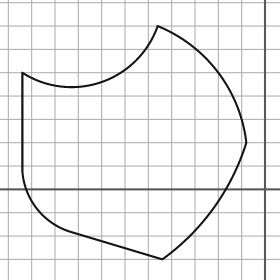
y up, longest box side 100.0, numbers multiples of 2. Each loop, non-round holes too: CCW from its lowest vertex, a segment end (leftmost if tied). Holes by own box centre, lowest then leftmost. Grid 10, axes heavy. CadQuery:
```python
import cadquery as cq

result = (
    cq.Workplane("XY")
    .moveTo(-44.0, -30.0)
    .threePointArc((-22.0, -8.0), (-8.0, 20.0))
    .threePointArc((-20.0, 50.0), (-46.0, 70.0))
    .threePointArc((-70.0, 46.0), (-104.0, 50.0))
    .lineTo(-104.0, 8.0)
    .threePointArc((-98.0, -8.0), (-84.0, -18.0))
    .close()
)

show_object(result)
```